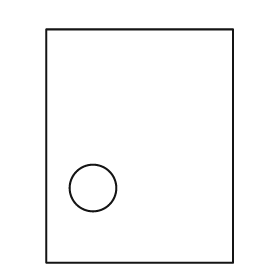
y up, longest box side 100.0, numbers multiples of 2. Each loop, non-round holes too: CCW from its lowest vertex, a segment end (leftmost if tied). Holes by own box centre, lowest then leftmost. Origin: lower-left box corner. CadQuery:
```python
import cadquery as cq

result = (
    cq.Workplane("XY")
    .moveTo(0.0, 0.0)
    .lineTo(80.0, 0.0)
    .lineTo(80.0, 100.0)
    .lineTo(0.0, 100.0)
    .close()
    .moveTo(20.0, 32.0)
    .circle(10.0)
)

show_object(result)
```